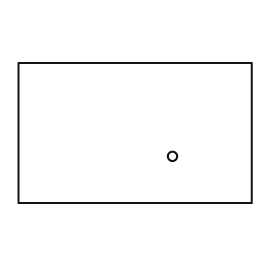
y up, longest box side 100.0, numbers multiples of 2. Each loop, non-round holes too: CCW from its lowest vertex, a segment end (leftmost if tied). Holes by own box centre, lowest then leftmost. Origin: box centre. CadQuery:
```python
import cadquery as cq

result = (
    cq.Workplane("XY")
    .moveTo(-50.0, -30.0)
    .lineTo(50.0, -30.0)
    .lineTo(50.0, 30.0)
    .lineTo(-50.0, 30.0)
    .close()
    .moveTo(16.0, -10.0)
    .circle(2.0)
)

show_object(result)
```